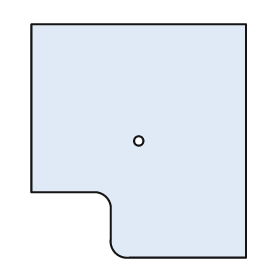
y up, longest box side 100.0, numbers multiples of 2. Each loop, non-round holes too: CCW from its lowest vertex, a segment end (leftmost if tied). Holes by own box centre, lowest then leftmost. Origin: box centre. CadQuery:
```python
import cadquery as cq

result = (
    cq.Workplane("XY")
    .moveTo(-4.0, -50.0)
    .lineTo(46.0, -50.0)
    .lineTo(46.0, 50.0)
    .lineTo(-46.0, 50.0)
    .lineTo(-46.0, -22.0)
    .lineTo(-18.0, -22.0)
    .threePointArc((-14.0, -24.0), (-12.0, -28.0))
    .lineTo(-12.0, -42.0)
    .threePointArc((-10.0, -48.0), (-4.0, -50.0))
    .close()
    .moveTo(0.0, 0.0)
    .circle(2.0)
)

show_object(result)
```